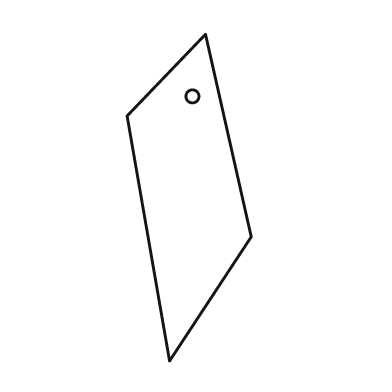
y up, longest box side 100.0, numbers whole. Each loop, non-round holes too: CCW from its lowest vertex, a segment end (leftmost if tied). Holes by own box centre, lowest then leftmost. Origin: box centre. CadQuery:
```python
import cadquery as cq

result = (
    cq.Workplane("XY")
    .moveTo(-6.0, -50.0)
    .lineTo(19.0, -12.0)
    .lineTo(5.0, 50.0)
    .lineTo(-19.0, 25.0)
    .close()
    .moveTo(1.0, 31.0)
    .circle(2.0)
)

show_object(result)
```